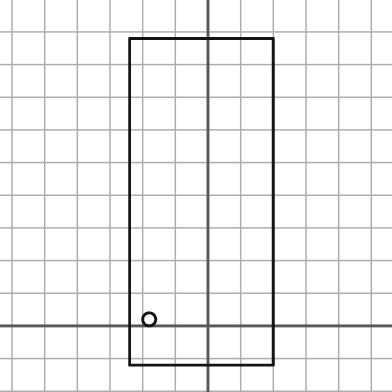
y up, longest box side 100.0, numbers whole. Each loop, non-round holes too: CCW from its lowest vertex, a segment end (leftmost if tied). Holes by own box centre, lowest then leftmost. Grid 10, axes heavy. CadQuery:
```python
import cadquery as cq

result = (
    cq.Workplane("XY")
    .moveTo(-24.0, -12.0)
    .lineTo(20.0, -12.0)
    .lineTo(20.0, 88.0)
    .lineTo(-24.0, 88.0)
    .close()
    .moveTo(-18.0, 2.0)
    .circle(2.0)
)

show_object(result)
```